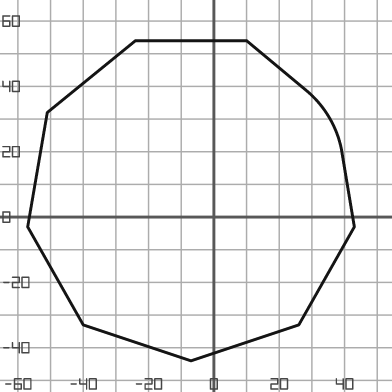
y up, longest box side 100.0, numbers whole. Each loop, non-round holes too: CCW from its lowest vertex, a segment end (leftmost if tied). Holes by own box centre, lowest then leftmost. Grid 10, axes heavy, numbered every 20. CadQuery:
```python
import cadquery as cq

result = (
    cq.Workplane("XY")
    .moveTo(-7.0, -44.0)
    .lineTo(26.0, -33.0)
    .lineTo(43.0, -3.0)
    .lineTo(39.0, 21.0)
    .threePointArc((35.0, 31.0), (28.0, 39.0))
    .lineTo(10.0, 54.0)
    .lineTo(-24.0, 54.0)
    .lineTo(-51.0, 32.0)
    .lineTo(-57.0, -3.0)
    .lineTo(-40.0, -33.0)
    .close()
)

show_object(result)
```